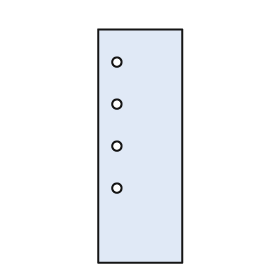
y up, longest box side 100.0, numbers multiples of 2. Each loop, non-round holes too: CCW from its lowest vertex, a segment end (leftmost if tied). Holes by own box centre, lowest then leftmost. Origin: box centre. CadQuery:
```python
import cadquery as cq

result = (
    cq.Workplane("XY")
    .moveTo(-18.0, -50.0)
    .lineTo(18.0, -50.0)
    .lineTo(18.0, 50.0)
    .lineTo(-18.0, 50.0)
    .close()
    .moveTo(-10.0, -18.0)
    .circle(2.0)
    .moveTo(-10.0, 0.0)
    .circle(2.0)
    .moveTo(-10.0, 18.0)
    .circle(2.0)
    .moveTo(-10.0, 36.0)
    .circle(2.0)
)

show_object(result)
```